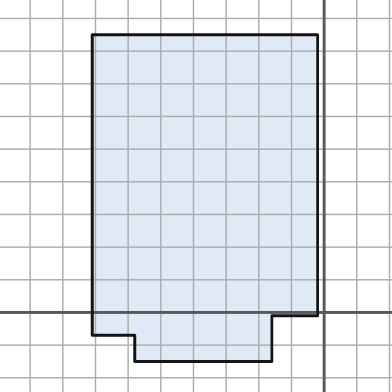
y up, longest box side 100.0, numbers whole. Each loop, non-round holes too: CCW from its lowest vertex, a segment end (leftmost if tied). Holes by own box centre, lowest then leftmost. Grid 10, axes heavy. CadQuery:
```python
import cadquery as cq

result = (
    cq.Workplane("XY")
    .moveTo(-58.0, -15.0)
    .lineTo(-16.0, -15.0)
    .lineTo(-16.0, -1.0)
    .lineTo(-2.0, -1.0)
    .lineTo(-2.0, 85.0)
    .lineTo(-71.0, 85.0)
    .lineTo(-71.0, -7.0)
    .lineTo(-58.0, -7.0)
    .close()
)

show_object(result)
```